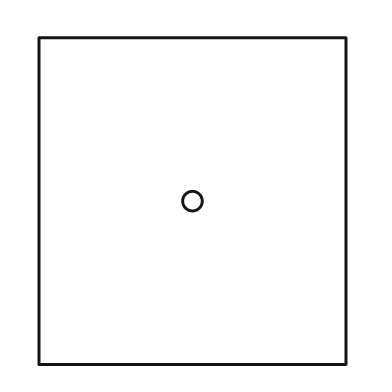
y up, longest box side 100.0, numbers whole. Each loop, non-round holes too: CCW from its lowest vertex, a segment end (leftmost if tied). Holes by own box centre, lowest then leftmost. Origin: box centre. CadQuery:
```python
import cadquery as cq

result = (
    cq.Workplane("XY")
    .moveTo(-47.0, -50.0)
    .lineTo(47.0, -50.0)
    .lineTo(47.0, 50.0)
    .lineTo(-47.0, 50.0)
    .close()
    .moveTo(0.0, 0.0)
    .circle(3.0)
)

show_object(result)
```